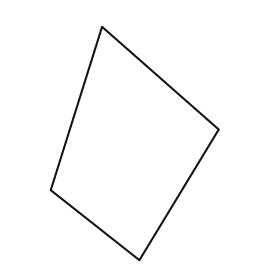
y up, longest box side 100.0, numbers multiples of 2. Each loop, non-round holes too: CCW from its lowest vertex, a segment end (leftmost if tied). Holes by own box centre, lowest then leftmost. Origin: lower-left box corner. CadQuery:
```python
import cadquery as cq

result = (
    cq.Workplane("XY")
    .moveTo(38.0, 0.0)
    .lineTo(72.0, 56.0)
    .lineTo(22.0, 100.0)
    .lineTo(0.0, 30.0)
    .close()
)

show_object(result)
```